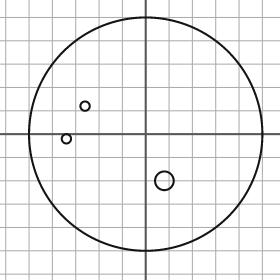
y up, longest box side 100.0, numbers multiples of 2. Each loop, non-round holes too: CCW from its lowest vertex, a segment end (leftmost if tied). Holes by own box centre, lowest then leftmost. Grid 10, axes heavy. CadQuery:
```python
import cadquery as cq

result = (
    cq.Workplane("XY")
    .moveTo(0.0, 0.0)
    .circle(50.0)
    .moveTo(8.0, -20.0)
    .circle(4.0)
    .moveTo(-34.0, -2.0)
    .circle(2.0)
    .moveTo(-26.0, 12.0)
    .circle(2.0)
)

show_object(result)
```